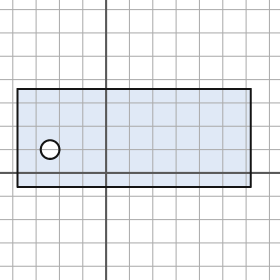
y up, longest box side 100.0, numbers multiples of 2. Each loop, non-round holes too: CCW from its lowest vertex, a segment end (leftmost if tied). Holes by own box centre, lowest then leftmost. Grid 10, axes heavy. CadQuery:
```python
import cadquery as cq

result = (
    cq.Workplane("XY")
    .moveTo(-38.0, -6.0)
    .lineTo(62.0, -6.0)
    .lineTo(62.0, 36.0)
    .lineTo(-38.0, 36.0)
    .close()
    .moveTo(-24.0, 10.0)
    .circle(4.0)
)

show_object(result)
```